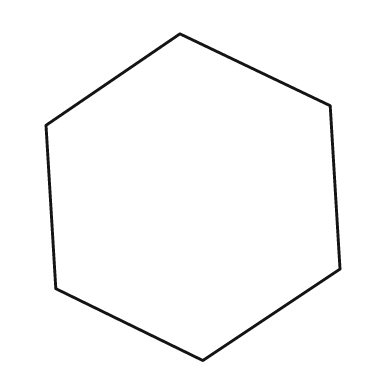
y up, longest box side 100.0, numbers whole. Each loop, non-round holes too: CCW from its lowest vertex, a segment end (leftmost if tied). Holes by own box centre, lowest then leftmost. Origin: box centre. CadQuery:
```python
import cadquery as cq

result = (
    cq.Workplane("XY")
    .moveTo(3.0, -50.0)
    .lineTo(45.0, -22.0)
    .lineTo(42.0, 28.0)
    .lineTo(-4.0, 50.0)
    .lineTo(-45.0, 22.0)
    .lineTo(-42.0, -28.0)
    .close()
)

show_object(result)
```